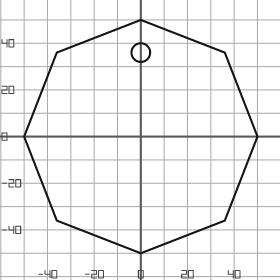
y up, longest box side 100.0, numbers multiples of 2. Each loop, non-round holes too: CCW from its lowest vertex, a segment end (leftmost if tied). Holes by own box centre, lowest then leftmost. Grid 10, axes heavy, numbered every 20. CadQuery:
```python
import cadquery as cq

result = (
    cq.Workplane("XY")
    .moveTo(0.0, -50.0)
    .lineTo(36.0, -36.0)
    .lineTo(50.0, 0.0)
    .lineTo(36.0, 36.0)
    .lineTo(0.0, 50.0)
    .lineTo(-36.0, 36.0)
    .lineTo(-50.0, 0.0)
    .lineTo(-36.0, -36.0)
    .close()
    .moveTo(0.0, 36.0)
    .circle(4.0)
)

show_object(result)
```